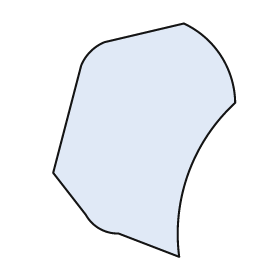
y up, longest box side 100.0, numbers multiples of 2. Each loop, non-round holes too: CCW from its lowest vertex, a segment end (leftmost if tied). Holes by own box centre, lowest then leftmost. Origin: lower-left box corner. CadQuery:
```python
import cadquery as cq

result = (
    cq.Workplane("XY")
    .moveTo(54.0, 0.0)
    .threePointArc((58.0, 36.0), (78.0, 66.0))
    .threePointArc((72.0, 86.0), (56.0, 100.0))
    .lineTo(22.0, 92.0)
    .threePointArc((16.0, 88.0), (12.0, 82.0))
    .lineTo(0.0, 36.0)
    .lineTo(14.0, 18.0)
    .threePointArc((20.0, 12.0), (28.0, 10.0))
    .close()
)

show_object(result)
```